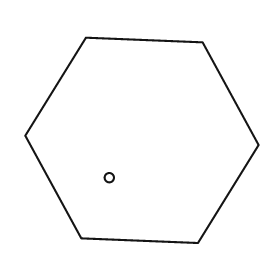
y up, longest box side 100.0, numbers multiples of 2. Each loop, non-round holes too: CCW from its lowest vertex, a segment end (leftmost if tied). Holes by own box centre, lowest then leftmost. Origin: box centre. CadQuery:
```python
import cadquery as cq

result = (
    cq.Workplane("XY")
    .moveTo(24.0, -44.0)
    .lineTo(50.0, -2.0)
    .lineTo(26.0, 42.0)
    .lineTo(-24.0, 44.0)
    .lineTo(-50.0, 2.0)
    .lineTo(-26.0, -42.0)
    .close()
    .moveTo(-14.0, -16.0)
    .circle(2.0)
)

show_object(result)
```